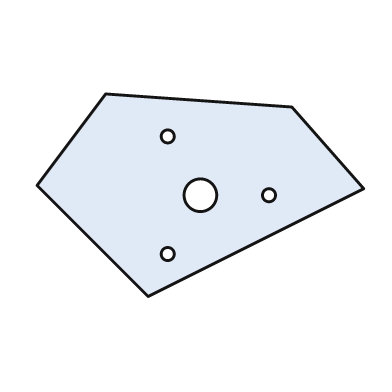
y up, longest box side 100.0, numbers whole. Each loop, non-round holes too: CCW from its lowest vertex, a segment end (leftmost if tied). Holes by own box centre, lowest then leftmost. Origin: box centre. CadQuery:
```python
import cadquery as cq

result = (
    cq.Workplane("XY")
    .moveTo(-16.0, -31.0)
    .lineTo(50.0, 2.0)
    .lineTo(28.0, 27.0)
    .lineTo(-29.0, 31.0)
    .lineTo(-50.0, 3.0)
    .close()
    .moveTo(-10.0, -18.0)
    .circle(2.0)
    .moveTo(0.0, 0.0)
    .circle(5.0)
    .moveTo(21.0, 0.0)
    .circle(2.0)
    .moveTo(-10.0, 18.0)
    .circle(2.0)
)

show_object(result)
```